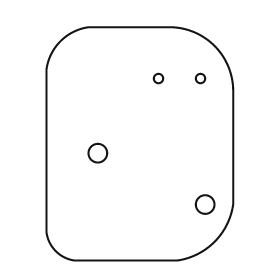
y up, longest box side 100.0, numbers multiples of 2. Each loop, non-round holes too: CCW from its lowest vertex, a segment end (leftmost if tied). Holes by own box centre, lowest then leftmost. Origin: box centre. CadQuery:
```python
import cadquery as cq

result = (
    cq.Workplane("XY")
    .moveTo(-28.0, -50.0)
    .lineTo(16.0, -50.0)
    .threePointArc((32.0, -42.0), (40.0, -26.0))
    .lineTo(40.0, 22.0)
    .threePointArc((32.0, 42.0), (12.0, 50.0))
    .lineTo(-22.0, 50.0)
    .threePointArc((-34.0, 44.0), (-40.0, 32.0))
    .lineTo(-40.0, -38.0)
    .threePointArc((-36.0, -46.0), (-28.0, -50.0))
    .close()
    .moveTo(28.0, -26.0)
    .circle(4.0)
    .moveTo(-18.0, -4.0)
    .circle(4.0)
    .moveTo(8.0, 28.0)
    .circle(2.0)
    .moveTo(26.0, 28.0)
    .circle(2.0)
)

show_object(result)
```